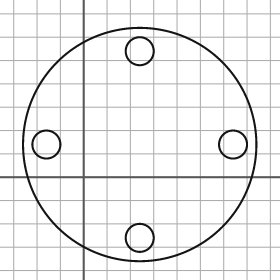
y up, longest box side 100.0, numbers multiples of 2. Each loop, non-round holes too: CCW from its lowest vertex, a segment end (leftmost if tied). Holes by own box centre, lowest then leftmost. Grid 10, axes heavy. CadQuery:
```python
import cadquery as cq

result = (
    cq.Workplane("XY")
    .moveTo(24.0, 14.0)
    .circle(50.0)
    .moveTo(24.0, -26.0)
    .circle(6.0)
    .moveTo(-16.0, 14.0)
    .circle(6.0)
    .moveTo(64.0, 14.0)
    .circle(6.0)
    .moveTo(24.0, 54.0)
    .circle(6.0)
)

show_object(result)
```